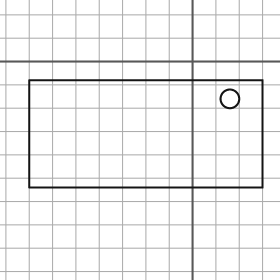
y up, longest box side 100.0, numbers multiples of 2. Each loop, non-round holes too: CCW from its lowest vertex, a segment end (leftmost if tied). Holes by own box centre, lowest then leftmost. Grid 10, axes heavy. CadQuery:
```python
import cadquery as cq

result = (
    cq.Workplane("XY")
    .moveTo(-70.0, -54.0)
    .lineTo(30.0, -54.0)
    .lineTo(30.0, -8.0)
    .lineTo(-70.0, -8.0)
    .close()
    .moveTo(16.0, -16.0)
    .circle(4.0)
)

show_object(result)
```